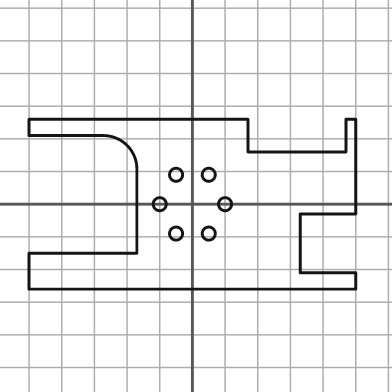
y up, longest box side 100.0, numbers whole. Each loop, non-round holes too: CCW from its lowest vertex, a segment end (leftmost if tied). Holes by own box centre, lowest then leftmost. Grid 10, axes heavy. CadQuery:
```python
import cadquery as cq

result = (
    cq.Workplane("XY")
    .moveTo(-50.0, -26.0)
    .lineTo(50.0, -26.0)
    .lineTo(50.0, -21.0)
    .lineTo(33.0, -21.0)
    .lineTo(33.0, -3.0)
    .lineTo(50.0, -3.0)
    .lineTo(50.0, 26.0)
    .lineTo(47.0, 26.0)
    .lineTo(47.0, 16.0)
    .lineTo(17.0, 16.0)
    .lineTo(17.0, 26.0)
    .lineTo(-50.0, 26.0)
    .lineTo(-50.0, 21.0)
    .lineTo(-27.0, 21.0)
    .threePointArc((-20.0, 18.0), (-17.0, 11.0))
    .lineTo(-17.0, -15.0)
    .lineTo(-50.0, -15.0)
    .close()
    .moveTo(-5.0, -9.0)
    .circle(2.0)
    .moveTo(5.0, -9.0)
    .circle(2.0)
    .moveTo(-10.0, 0.0)
    .circle(2.0)
    .moveTo(10.0, 0.0)
    .circle(2.0)
    .moveTo(-5.0, 9.0)
    .circle(2.0)
    .moveTo(5.0, 9.0)
    .circle(2.0)
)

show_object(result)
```